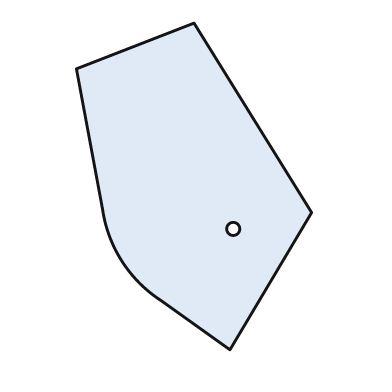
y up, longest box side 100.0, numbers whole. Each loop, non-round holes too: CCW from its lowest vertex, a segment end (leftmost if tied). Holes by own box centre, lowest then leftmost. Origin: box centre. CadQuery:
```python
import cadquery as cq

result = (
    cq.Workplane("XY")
    .moveTo(11.0, -50.0)
    .lineTo(36.0, -8.0)
    .lineTo(0.0, 50.0)
    .lineTo(-36.0, 36.0)
    .lineTo(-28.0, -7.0)
    .threePointArc((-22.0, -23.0), (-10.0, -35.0))
    .close()
    .moveTo(12.0, -13.0)
    .circle(2.0)
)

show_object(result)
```